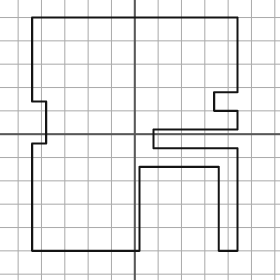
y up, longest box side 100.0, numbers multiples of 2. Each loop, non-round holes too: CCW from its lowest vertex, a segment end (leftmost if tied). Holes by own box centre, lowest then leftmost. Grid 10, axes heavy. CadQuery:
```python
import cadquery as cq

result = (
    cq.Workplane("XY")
    .moveTo(-44.0, -50.0)
    .lineTo(2.0, -50.0)
    .lineTo(2.0, -14.0)
    .lineTo(36.0, -14.0)
    .lineTo(36.0, -50.0)
    .lineTo(44.0, -50.0)
    .lineTo(44.0, -6.0)
    .lineTo(8.0, -6.0)
    .lineTo(8.0, 2.0)
    .lineTo(44.0, 2.0)
    .lineTo(44.0, 10.0)
    .lineTo(34.0, 10.0)
    .lineTo(34.0, 18.0)
    .lineTo(44.0, 18.0)
    .lineTo(44.0, 50.0)
    .lineTo(-44.0, 50.0)
    .lineTo(-44.0, 14.0)
    .lineTo(-38.0, 14.0)
    .lineTo(-38.0, -4.0)
    .lineTo(-44.0, -4.0)
    .close()
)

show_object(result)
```